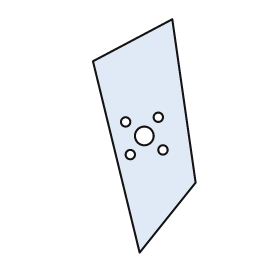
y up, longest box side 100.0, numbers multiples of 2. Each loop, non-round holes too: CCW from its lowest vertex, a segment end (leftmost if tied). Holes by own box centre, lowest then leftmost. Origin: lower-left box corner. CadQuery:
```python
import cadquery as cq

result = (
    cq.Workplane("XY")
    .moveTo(20.0, 0.0)
    .lineTo(44.0, 30.0)
    .lineTo(34.0, 100.0)
    .lineTo(0.0, 82.0)
    .close()
    .moveTo(16.0, 42.0)
    .circle(2.0)
    .moveTo(30.0, 44.0)
    .circle(2.0)
    .moveTo(22.0, 50.0)
    .circle(4.0)
    .moveTo(14.0, 56.0)
    .circle(2.0)
    .moveTo(28.0, 58.0)
    .circle(2.0)
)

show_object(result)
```